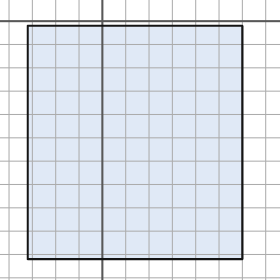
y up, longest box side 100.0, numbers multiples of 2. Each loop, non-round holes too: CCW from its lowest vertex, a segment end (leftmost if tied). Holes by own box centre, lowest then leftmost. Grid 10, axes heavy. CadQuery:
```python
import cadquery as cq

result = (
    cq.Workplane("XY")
    .moveTo(-32.0, -102.0)
    .lineTo(60.0, -102.0)
    .lineTo(60.0, -2.0)
    .lineTo(-32.0, -2.0)
    .close()
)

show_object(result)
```